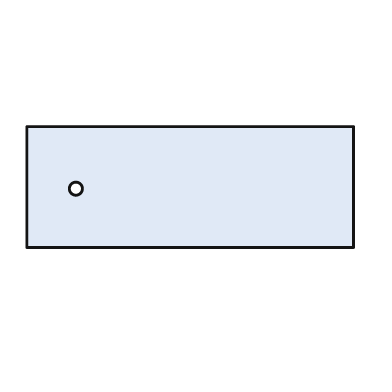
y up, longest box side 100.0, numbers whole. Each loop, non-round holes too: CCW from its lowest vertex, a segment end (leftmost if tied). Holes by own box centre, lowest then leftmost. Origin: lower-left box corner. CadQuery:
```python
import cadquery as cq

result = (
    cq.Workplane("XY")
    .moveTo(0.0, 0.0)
    .lineTo(100.0, 0.0)
    .lineTo(100.0, 37.0)
    .lineTo(0.0, 37.0)
    .close()
    .moveTo(15.0, 18.0)
    .circle(2.0)
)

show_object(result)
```